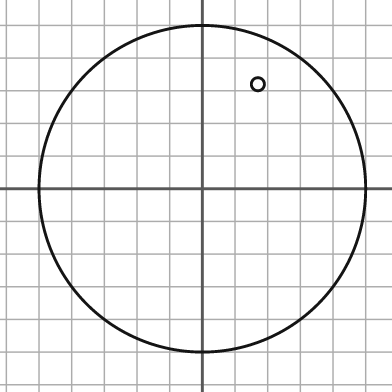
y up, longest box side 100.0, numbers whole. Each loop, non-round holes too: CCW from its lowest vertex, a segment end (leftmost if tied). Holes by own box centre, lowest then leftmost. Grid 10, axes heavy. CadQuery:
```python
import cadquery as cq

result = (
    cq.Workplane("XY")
    .moveTo(0.0, 0.0)
    .circle(50.0)
    .moveTo(17.0, 32.0)
    .circle(2.0)
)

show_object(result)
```